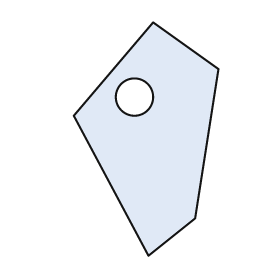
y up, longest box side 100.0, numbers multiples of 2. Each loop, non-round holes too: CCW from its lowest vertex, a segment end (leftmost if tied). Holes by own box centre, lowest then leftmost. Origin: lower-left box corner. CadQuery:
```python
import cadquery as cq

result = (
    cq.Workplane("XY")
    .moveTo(32.0, 0.0)
    .lineTo(52.0, 16.0)
    .lineTo(62.0, 80.0)
    .lineTo(34.0, 100.0)
    .lineTo(0.0, 60.0)
    .close()
    .moveTo(26.0, 68.0)
    .circle(8.0)
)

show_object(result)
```